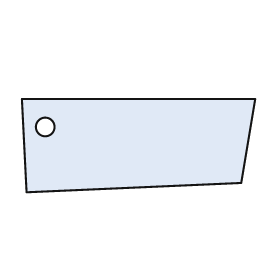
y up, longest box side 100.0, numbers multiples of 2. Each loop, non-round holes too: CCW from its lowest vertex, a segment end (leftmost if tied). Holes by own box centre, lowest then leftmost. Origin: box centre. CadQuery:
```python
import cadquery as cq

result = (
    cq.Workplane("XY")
    .moveTo(-48.0, -20.0)
    .lineTo(44.0, -16.0)
    .lineTo(50.0, 20.0)
    .lineTo(-50.0, 20.0)
    .close()
    .moveTo(-40.0, 8.0)
    .circle(4.0)
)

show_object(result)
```